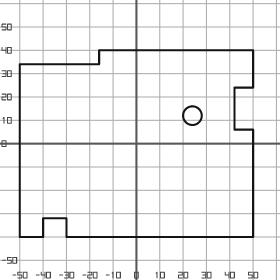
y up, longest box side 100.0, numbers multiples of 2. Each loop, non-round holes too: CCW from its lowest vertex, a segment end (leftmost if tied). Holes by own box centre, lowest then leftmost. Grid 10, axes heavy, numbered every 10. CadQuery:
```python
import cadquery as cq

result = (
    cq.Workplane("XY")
    .moveTo(-50.0, -40.0)
    .lineTo(-40.0, -40.0)
    .lineTo(-40.0, -32.0)
    .lineTo(-30.0, -32.0)
    .lineTo(-30.0, -40.0)
    .lineTo(50.0, -40.0)
    .lineTo(50.0, 6.0)
    .lineTo(42.0, 6.0)
    .lineTo(42.0, 24.0)
    .lineTo(50.0, 24.0)
    .lineTo(50.0, 40.0)
    .lineTo(-16.0, 40.0)
    .lineTo(-16.0, 34.0)
    .lineTo(-50.0, 34.0)
    .close()
    .moveTo(24.0, 12.0)
    .circle(4.0)
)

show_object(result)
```